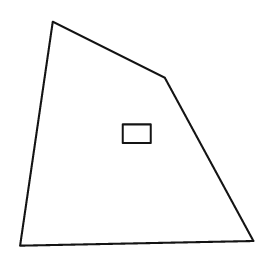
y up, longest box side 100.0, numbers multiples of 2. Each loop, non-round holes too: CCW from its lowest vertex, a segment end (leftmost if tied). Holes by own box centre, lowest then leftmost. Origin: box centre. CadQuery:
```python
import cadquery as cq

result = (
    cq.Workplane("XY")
    .moveTo(-50.0, -48.0)
    .lineTo(50.0, -46.0)
    .lineTo(12.0, 24.0)
    .lineTo(-36.0, 48.0)
    .close()
    .moveTo(-6.0, -4.0)
    .lineTo(6.0, -4.0)
    .lineTo(6.0, 4.0)
    .lineTo(-6.0, 4.0)
    .close()
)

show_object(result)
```